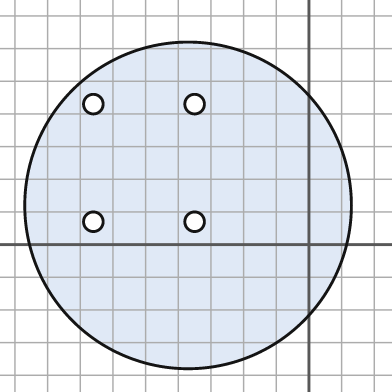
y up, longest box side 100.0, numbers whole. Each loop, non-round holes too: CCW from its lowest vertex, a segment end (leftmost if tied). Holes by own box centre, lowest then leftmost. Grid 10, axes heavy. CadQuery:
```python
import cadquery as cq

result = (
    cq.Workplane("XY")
    .moveTo(-37.0, 12.0)
    .circle(50.0)
    .moveTo(-66.0, 7.0)
    .circle(3.0)
    .moveTo(-35.0, 7.0)
    .circle(3.0)
    .moveTo(-66.0, 43.0)
    .circle(3.0)
    .moveTo(-35.0, 43.0)
    .circle(3.0)
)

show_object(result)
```